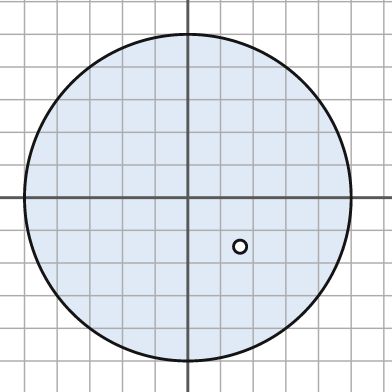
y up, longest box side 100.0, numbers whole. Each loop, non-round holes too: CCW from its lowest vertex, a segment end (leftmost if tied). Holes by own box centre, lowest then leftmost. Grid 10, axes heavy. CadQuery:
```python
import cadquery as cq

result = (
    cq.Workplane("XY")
    .moveTo(0.0, 0.0)
    .circle(50.0)
    .moveTo(16.0, -15.0)
    .circle(2.0)
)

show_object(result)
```